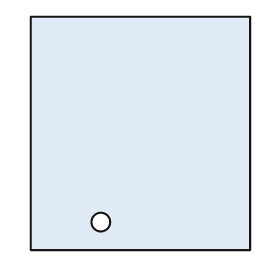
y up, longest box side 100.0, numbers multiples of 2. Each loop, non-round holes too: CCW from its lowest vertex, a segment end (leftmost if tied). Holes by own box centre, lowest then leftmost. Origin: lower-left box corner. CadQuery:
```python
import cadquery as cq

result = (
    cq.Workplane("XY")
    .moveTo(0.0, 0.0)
    .lineTo(94.0, 0.0)
    .lineTo(94.0, 100.0)
    .lineTo(0.0, 100.0)
    .close()
    .moveTo(30.0, 12.0)
    .circle(4.0)
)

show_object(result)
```